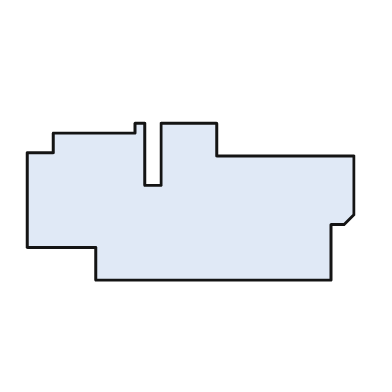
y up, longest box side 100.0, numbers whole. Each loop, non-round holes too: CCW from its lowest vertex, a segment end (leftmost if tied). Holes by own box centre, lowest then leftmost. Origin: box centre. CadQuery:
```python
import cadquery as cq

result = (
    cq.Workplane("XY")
    .moveTo(-29.0, -24.0)
    .lineTo(43.0, -24.0)
    .lineTo(43.0, -7.0)
    .lineTo(47.0, -7.0)
    .lineTo(50.0, -4.0)
    .lineTo(50.0, 14.0)
    .lineTo(8.0, 14.0)
    .lineTo(8.0, 24.0)
    .lineTo(-9.0, 24.0)
    .lineTo(-9.0, 5.0)
    .lineTo(-14.0, 5.0)
    .lineTo(-14.0, 24.0)
    .lineTo(-17.0, 24.0)
    .lineTo(-17.0, 21.0)
    .lineTo(-42.0, 21.0)
    .lineTo(-42.0, 15.0)
    .lineTo(-50.0, 15.0)
    .lineTo(-50.0, -14.0)
    .lineTo(-29.0, -14.0)
    .close()
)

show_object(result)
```